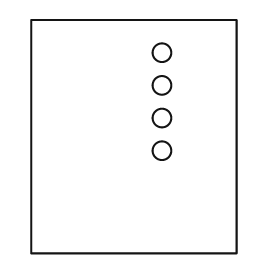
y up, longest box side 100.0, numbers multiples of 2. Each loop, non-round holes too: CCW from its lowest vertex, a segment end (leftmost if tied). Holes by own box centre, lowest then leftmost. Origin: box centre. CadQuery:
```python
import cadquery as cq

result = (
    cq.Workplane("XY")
    .moveTo(-44.0, -50.0)
    .lineTo(44.0, -50.0)
    .lineTo(44.0, 50.0)
    .lineTo(-44.0, 50.0)
    .close()
    .moveTo(12.0, -6.0)
    .circle(4.0)
    .moveTo(12.0, 8.0)
    .circle(4.0)
    .moveTo(12.0, 22.0)
    .circle(4.0)
    .moveTo(12.0, 36.0)
    .circle(4.0)
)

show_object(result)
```